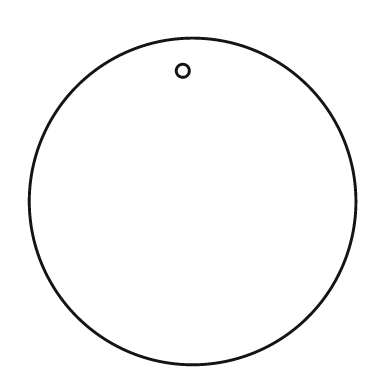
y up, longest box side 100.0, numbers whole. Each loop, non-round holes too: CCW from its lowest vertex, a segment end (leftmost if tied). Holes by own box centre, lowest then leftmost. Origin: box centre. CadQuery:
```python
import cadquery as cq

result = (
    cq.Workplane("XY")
    .moveTo(0.0, 0.0)
    .circle(50.0)
    .moveTo(-3.0, 40.0)
    .circle(2.0)
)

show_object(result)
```